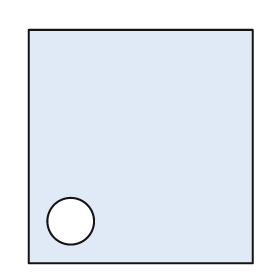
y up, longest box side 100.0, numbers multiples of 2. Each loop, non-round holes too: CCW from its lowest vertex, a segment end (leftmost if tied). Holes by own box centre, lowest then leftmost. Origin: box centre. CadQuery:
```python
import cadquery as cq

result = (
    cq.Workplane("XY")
    .moveTo(-48.0, -50.0)
    .lineTo(48.0, -50.0)
    .lineTo(48.0, 50.0)
    .lineTo(-48.0, 50.0)
    .close()
    .moveTo(-30.0, -32.0)
    .circle(10.0)
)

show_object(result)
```